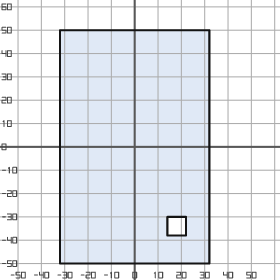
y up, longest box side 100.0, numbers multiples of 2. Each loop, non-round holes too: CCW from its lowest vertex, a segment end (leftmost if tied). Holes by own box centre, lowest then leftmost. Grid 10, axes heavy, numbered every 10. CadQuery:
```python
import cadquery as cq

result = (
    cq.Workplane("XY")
    .moveTo(-32.0, -50.0)
    .lineTo(32.0, -50.0)
    .lineTo(32.0, 50.0)
    .lineTo(-32.0, 50.0)
    .close()
    .moveTo(14.0, -38.0)
    .lineTo(22.0, -38.0)
    .lineTo(22.0, -30.0)
    .lineTo(14.0, -30.0)
    .close()
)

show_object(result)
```